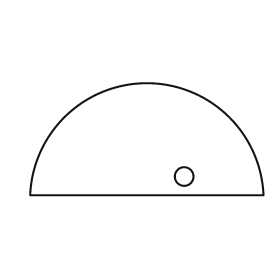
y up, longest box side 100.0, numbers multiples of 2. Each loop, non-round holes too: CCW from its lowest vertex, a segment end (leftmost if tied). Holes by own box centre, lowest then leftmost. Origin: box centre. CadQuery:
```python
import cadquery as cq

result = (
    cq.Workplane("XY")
    .moveTo(-50.0, -24.0)
    .lineTo(50.0, -24.0)
    .threePointArc((0.0, 24.0), (-50.0, -24.0))
    .close()
    .moveTo(16.0, -16.0)
    .circle(4.0)
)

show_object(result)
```